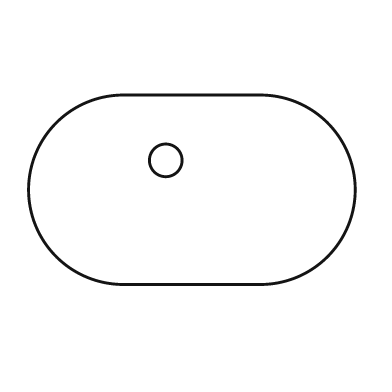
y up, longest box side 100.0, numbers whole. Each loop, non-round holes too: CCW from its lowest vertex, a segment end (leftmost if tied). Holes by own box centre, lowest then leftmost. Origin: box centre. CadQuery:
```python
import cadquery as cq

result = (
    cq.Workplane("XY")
    .moveTo(-21.0, -29.0)
    .lineTo(21.0, -29.0)
    .threePointArc((50.0, 0.0), (21.0, 29.0))
    .lineTo(-21.0, 29.0)
    .threePointArc((-50.0, 0.0), (-21.0, -29.0))
    .close()
    .moveTo(-8.0, 9.0)
    .circle(5.0)
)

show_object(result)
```